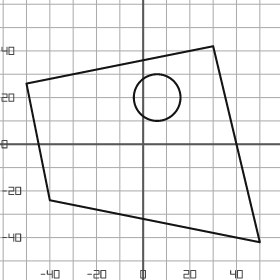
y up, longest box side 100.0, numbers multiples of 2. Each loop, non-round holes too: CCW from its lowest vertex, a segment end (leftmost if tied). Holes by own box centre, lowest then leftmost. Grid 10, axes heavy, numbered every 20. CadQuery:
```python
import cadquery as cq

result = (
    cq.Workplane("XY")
    .moveTo(50.0, -42.0)
    .lineTo(30.0, 42.0)
    .lineTo(-50.0, 26.0)
    .lineTo(-40.0, -24.0)
    .close()
    .moveTo(6.0, 20.0)
    .circle(10.0)
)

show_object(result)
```